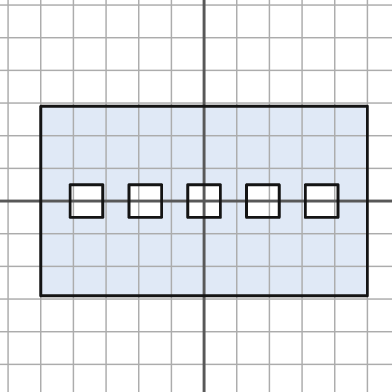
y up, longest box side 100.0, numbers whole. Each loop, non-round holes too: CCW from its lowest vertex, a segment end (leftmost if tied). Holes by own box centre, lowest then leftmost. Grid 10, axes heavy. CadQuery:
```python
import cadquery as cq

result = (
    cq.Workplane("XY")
    .moveTo(-50.0, -29.0)
    .lineTo(50.0, -29.0)
    .lineTo(50.0, 29.0)
    .lineTo(-50.0, 29.0)
    .close()
    .moveTo(-41.0, -5.0)
    .lineTo(-31.0, -5.0)
    .lineTo(-31.0, 5.0)
    .lineTo(-41.0, 5.0)
    .close()
    .moveTo(-23.0, -5.0)
    .lineTo(-13.0, -5.0)
    .lineTo(-13.0, 5.0)
    .lineTo(-23.0, 5.0)
    .close()
    .moveTo(-5.0, -5.0)
    .lineTo(5.0, -5.0)
    .lineTo(5.0, 5.0)
    .lineTo(-5.0, 5.0)
    .close()
    .moveTo(13.0, -5.0)
    .lineTo(23.0, -5.0)
    .lineTo(23.0, 5.0)
    .lineTo(13.0, 5.0)
    .close()
    .moveTo(31.0, -5.0)
    .lineTo(41.0, -5.0)
    .lineTo(41.0, 5.0)
    .lineTo(31.0, 5.0)
    .close()
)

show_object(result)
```